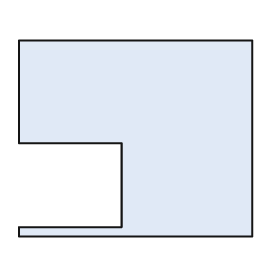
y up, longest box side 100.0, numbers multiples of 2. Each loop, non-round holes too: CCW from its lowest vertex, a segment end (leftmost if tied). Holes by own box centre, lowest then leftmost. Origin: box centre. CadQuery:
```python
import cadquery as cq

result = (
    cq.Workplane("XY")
    .moveTo(-50.0, -42.0)
    .lineTo(50.0, -42.0)
    .lineTo(50.0, 42.0)
    .lineTo(-50.0, 42.0)
    .lineTo(-50.0, -2.0)
    .lineTo(-6.0, -2.0)
    .lineTo(-6.0, -38.0)
    .lineTo(-50.0, -38.0)
    .close()
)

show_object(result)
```